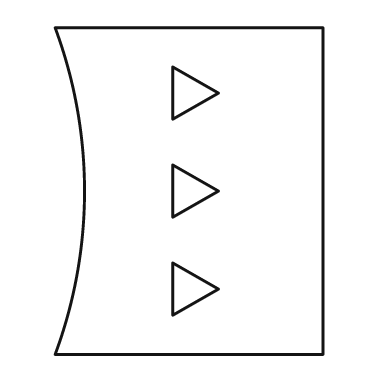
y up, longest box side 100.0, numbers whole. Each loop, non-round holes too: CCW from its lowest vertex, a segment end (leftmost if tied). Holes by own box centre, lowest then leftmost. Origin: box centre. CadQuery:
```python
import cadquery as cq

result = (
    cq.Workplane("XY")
    .moveTo(-41.0, -50.0)
    .lineTo(41.0, -50.0)
    .lineTo(41.0, 50.0)
    .lineTo(-41.0, 50.0)
    .threePointArc((-32.0, 0.0), (-41.0, -50.0))
    .close()
    .moveTo(-5.0, -38.0)
    .lineTo(9.0, -30.0)
    .lineTo(-5.0, -22.0)
    .close()
    .moveTo(-5.0, -8.0)
    .lineTo(9.0, 0.0)
    .lineTo(-5.0, 8.0)
    .close()
    .moveTo(-5.0, 22.0)
    .lineTo(9.0, 30.0)
    .lineTo(-5.0, 38.0)
    .close()
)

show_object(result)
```